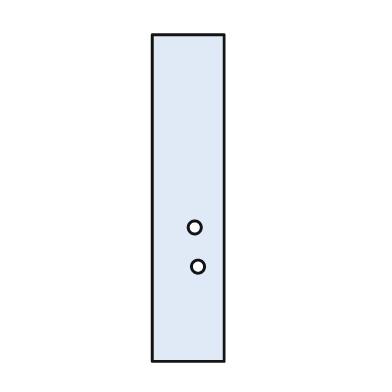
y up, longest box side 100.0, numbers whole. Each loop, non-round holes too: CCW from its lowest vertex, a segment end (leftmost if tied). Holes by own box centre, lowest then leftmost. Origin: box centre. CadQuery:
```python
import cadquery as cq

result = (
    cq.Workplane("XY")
    .moveTo(-11.0, -50.0)
    .lineTo(11.0, -50.0)
    .lineTo(11.0, 50.0)
    .lineTo(-11.0, 50.0)
    .close()
    .moveTo(3.0, -21.0)
    .circle(2.0)
    .moveTo(2.0, -9.0)
    .circle(2.0)
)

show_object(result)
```